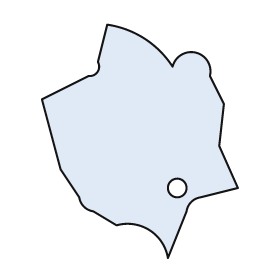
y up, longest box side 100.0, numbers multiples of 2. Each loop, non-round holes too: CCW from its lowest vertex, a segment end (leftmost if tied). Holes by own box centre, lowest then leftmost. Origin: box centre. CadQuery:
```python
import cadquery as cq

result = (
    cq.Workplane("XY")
    .moveTo(12.0, -50.0)
    .lineTo(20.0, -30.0)
    .threePointArc((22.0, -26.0), (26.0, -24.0))
    .lineTo(42.0, -20.0)
    .lineTo(34.0, -2.0)
    .lineTo(36.0, 16.0)
    .lineTo(30.0, 28.0)
    .threePointArc((24.0, 38.0), (14.0, 32.0))
    .threePointArc((2.0, 44.0), (-14.0, 50.0))
    .lineTo(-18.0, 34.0)
    .threePointArc((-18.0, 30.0), (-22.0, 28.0))
    .lineTo(-42.0, 18.0)
    .lineTo(-34.0, -12.0)
    .lineTo(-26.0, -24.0)
    .threePointArc((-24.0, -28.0), (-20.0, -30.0))
    .lineTo(-10.0, -36.0)
    .threePointArc((4.0, -38.0), (12.0, -50.0))
    .close()
    .moveTo(16.0, -20.0)
    .circle(4.0)
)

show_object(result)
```